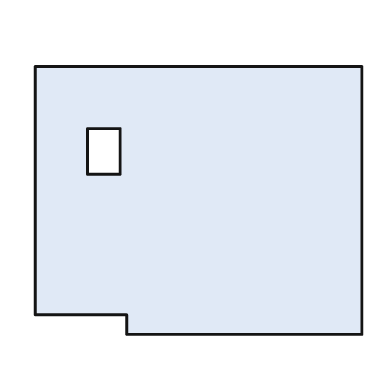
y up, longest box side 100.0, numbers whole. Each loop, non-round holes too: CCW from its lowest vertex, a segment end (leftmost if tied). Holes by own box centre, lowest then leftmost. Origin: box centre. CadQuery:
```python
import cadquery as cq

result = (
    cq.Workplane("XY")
    .moveTo(-22.0, -41.0)
    .lineTo(50.0, -41.0)
    .lineTo(50.0, 41.0)
    .lineTo(-50.0, 41.0)
    .lineTo(-50.0, -35.0)
    .lineTo(-22.0, -35.0)
    .close()
    .moveTo(-34.0, 8.0)
    .lineTo(-24.0, 8.0)
    .lineTo(-24.0, 22.0)
    .lineTo(-34.0, 22.0)
    .close()
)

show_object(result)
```